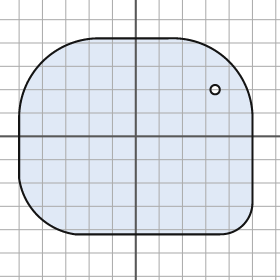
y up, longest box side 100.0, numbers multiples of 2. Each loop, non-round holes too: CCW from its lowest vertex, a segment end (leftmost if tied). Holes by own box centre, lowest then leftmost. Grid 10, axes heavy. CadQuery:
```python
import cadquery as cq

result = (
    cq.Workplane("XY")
    .moveTo(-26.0, -42.0)
    .lineTo(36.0, -42.0)
    .threePointArc((46.0, -38.0), (50.0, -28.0))
    .lineTo(50.0, 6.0)
    .threePointArc((40.0, 32.0), (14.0, 42.0))
    .lineTo(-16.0, 42.0)
    .threePointArc((-40.0, 32.0), (-50.0, 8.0))
    .lineTo(-50.0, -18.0)
    .threePointArc((-42.0, -34.0), (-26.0, -42.0))
    .close()
    .moveTo(34.0, 20.0)
    .circle(2.0)
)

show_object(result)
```